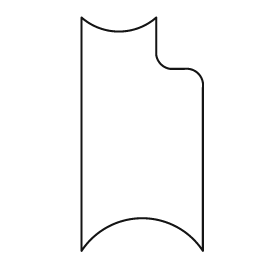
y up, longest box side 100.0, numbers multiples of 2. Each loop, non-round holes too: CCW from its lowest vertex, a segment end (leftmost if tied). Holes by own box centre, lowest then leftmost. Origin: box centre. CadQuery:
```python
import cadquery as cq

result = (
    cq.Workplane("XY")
    .moveTo(-26.0, -50.0)
    .threePointArc((0.0, -36.0), (26.0, -50.0))
    .lineTo(26.0, 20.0)
    .threePointArc((24.0, 26.0), (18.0, 28.0))
    .lineTo(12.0, 28.0)
    .threePointArc((8.0, 30.0), (6.0, 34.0))
    .lineTo(6.0, 50.0)
    .threePointArc((-10.0, 44.0), (-26.0, 50.0))
    .close()
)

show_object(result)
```